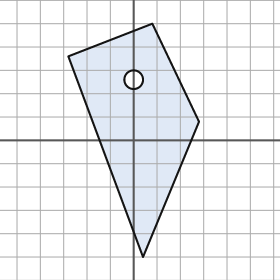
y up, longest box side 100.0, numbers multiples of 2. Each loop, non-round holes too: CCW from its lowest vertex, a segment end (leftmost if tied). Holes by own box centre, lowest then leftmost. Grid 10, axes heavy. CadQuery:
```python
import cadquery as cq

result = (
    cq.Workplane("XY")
    .moveTo(4.0, -50.0)
    .lineTo(28.0, 8.0)
    .lineTo(8.0, 50.0)
    .lineTo(-28.0, 36.0)
    .close()
    .moveTo(0.0, 26.0)
    .circle(4.0)
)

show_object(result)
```